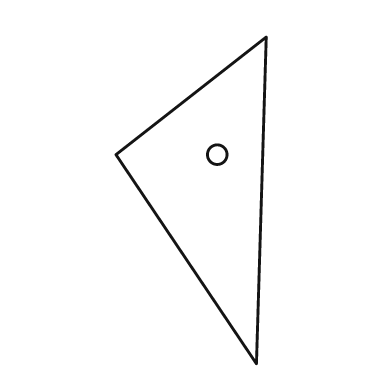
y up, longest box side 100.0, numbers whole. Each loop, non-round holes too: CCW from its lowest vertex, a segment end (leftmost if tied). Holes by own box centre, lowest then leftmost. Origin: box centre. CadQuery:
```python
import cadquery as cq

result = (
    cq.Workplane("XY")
    .moveTo(20.0, -50.0)
    .lineTo(23.0, 50.0)
    .lineTo(-23.0, 14.0)
    .close()
    .moveTo(8.0, 14.0)
    .circle(3.0)
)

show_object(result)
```